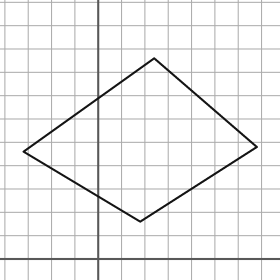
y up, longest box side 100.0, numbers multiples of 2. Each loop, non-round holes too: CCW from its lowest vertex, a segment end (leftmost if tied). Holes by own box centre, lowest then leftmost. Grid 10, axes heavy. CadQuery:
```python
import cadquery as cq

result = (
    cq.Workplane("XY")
    .moveTo(18.0, 16.0)
    .lineTo(68.0, 48.0)
    .lineTo(24.0, 86.0)
    .lineTo(-32.0, 46.0)
    .close()
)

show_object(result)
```